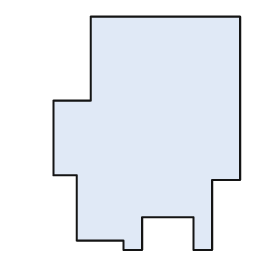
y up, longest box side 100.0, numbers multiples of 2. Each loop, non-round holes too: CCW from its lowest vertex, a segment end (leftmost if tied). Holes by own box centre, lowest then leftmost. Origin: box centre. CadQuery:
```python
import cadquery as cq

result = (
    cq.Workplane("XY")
    .moveTo(-10.0, -50.0)
    .lineTo(-2.0, -50.0)
    .lineTo(-2.0, -36.0)
    .lineTo(20.0, -36.0)
    .lineTo(20.0, -50.0)
    .lineTo(28.0, -50.0)
    .lineTo(28.0, -20.0)
    .lineTo(40.0, -20.0)
    .lineTo(40.0, 50.0)
    .lineTo(-24.0, 50.0)
    .lineTo(-24.0, 14.0)
    .lineTo(-40.0, 14.0)
    .lineTo(-40.0, -18.0)
    .lineTo(-30.0, -18.0)
    .lineTo(-30.0, -46.0)
    .lineTo(-10.0, -46.0)
    .close()
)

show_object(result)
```